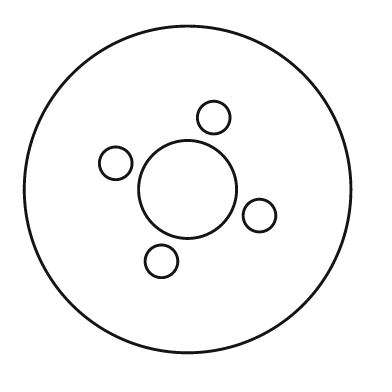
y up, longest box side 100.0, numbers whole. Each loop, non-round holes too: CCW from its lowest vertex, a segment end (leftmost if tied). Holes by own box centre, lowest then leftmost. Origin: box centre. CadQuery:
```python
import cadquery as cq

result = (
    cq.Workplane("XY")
    .moveTo(0.0, 0.0)
    .circle(50.0)
    .moveTo(-8.0, -22.0)
    .circle(5.0)
    .moveTo(22.0, -8.0)
    .circle(5.0)
    .moveTo(0.0, 0.0)
    .circle(15.0)
    .moveTo(-22.0, 8.0)
    .circle(5.0)
    .moveTo(8.0, 22.0)
    .circle(5.0)
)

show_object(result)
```